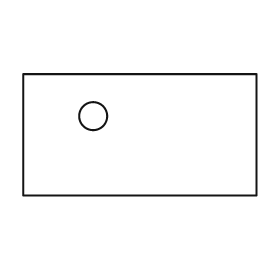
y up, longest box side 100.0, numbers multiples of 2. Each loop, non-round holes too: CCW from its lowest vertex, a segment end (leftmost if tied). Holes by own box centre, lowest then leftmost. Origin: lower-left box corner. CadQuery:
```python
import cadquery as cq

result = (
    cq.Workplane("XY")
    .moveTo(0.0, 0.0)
    .lineTo(100.0, 0.0)
    .lineTo(100.0, 52.0)
    .lineTo(0.0, 52.0)
    .close()
    .moveTo(30.0, 34.0)
    .circle(6.0)
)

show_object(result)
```